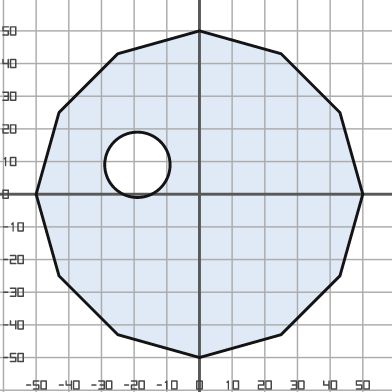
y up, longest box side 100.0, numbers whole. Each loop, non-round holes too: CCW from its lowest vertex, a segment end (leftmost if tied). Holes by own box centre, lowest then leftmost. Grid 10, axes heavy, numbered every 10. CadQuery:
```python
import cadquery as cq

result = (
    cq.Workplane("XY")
    .moveTo(0.0, -50.0)
    .lineTo(25.0, -43.0)
    .lineTo(43.0, -25.0)
    .lineTo(50.0, 0.0)
    .lineTo(43.0, 25.0)
    .lineTo(25.0, 43.0)
    .lineTo(0.0, 50.0)
    .lineTo(-25.0, 43.0)
    .lineTo(-43.0, 25.0)
    .lineTo(-50.0, 0.0)
    .lineTo(-43.0, -25.0)
    .lineTo(-25.0, -43.0)
    .close()
    .moveTo(-19.0, 9.0)
    .circle(10.0)
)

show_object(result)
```